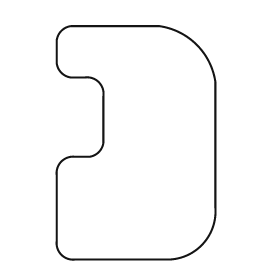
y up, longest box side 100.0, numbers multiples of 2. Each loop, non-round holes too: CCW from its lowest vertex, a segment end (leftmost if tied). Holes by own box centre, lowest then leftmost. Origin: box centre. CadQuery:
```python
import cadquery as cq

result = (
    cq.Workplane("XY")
    .moveTo(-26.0, -50.0)
    .lineTo(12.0, -50.0)
    .threePointArc((28.0, -44.0), (34.0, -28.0))
    .lineTo(34.0, 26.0)
    .threePointArc((26.0, 42.0), (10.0, 50.0))
    .lineTo(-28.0, 50.0)
    .threePointArc((-32.0, 48.0), (-34.0, 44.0))
    .lineTo(-34.0, 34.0)
    .threePointArc((-32.0, 30.0), (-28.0, 28.0))
    .lineTo(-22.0, 28.0)
    .threePointArc((-16.0, 26.0), (-14.0, 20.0))
    .lineTo(-14.0, 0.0)
    .threePointArc((-16.0, -4.0), (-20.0, -6.0))
    .lineTo(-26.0, -6.0)
    .threePointArc((-32.0, -8.0), (-34.0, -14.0))
    .lineTo(-34.0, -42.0)
    .threePointArc((-32.0, -48.0), (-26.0, -50.0))
    .close()
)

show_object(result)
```